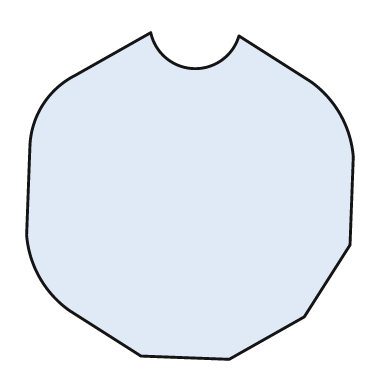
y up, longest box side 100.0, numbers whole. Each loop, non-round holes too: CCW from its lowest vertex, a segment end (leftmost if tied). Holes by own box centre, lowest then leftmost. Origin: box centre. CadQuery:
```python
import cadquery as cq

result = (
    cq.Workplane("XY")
    .moveTo(12.0, -50.0)
    .lineTo(35.0, -37.0)
    .lineTo(49.0, -15.0)
    .lineTo(50.0, 12.0)
    .threePointArc((46.0, 25.0), (37.0, 35.0))
    .lineTo(15.0, 49.0)
    .threePointArc((1.0, 39.0), (-12.0, 50.0))
    .lineTo(-35.0, 37.0)
    .threePointArc((-45.0, 28.0), (-49.0, 15.0))
    .lineTo(-50.0, -12.0)
    .threePointArc((-46.0, -25.0), (-37.0, -35.0))
    .lineTo(-15.0, -49.0)
    .close()
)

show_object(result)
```